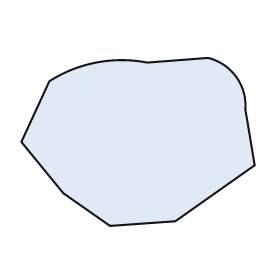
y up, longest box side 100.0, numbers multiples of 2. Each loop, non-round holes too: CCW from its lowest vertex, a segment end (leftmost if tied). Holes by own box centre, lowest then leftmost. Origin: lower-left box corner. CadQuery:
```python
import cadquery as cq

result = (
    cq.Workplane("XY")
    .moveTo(38.0, 0.0)
    .lineTo(66.0, 2.0)
    .lineTo(100.0, 26.0)
    .lineTo(96.0, 50.0)
    .threePointArc((92.0, 64.0), (80.0, 72.0))
    .lineTo(54.0, 70.0)
    .threePointArc((32.0, 70.0), (12.0, 62.0))
    .lineTo(0.0, 36.0)
    .lineTo(18.0, 14.0)
    .close()
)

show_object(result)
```